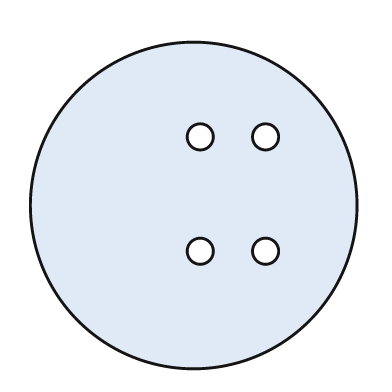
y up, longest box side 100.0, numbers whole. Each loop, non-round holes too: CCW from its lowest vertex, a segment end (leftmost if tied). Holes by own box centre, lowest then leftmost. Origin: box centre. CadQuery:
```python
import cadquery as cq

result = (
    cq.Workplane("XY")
    .moveTo(0.0, 0.0)
    .circle(50.0)
    .moveTo(2.0, -14.0)
    .circle(4.0)
    .moveTo(22.0, -14.0)
    .circle(4.0)
    .moveTo(2.0, 21.0)
    .circle(4.0)
    .moveTo(22.0, 21.0)
    .circle(4.0)
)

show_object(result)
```